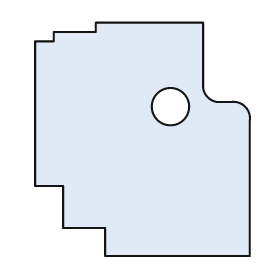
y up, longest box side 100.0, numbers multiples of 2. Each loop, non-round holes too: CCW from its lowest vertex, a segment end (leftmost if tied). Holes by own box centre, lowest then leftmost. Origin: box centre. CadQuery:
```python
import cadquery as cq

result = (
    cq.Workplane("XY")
    .moveTo(-16.0, -50.0)
    .lineTo(46.0, -50.0)
    .lineTo(46.0, 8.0)
    .threePointArc((44.0, 14.0), (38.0, 16.0))
    .lineTo(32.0, 16.0)
    .threePointArc((28.0, 18.0), (26.0, 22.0))
    .lineTo(26.0, 50.0)
    .lineTo(-20.0, 50.0)
    .lineTo(-20.0, 46.0)
    .lineTo(-38.0, 46.0)
    .lineTo(-38.0, 42.0)
    .lineTo(-46.0, 42.0)
    .lineTo(-46.0, -20.0)
    .lineTo(-34.0, -20.0)
    .lineTo(-34.0, -38.0)
    .lineTo(-16.0, -38.0)
    .close()
    .moveTo(12.0, 14.0)
    .circle(8.0)
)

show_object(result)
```